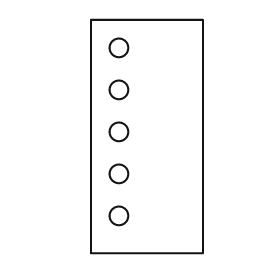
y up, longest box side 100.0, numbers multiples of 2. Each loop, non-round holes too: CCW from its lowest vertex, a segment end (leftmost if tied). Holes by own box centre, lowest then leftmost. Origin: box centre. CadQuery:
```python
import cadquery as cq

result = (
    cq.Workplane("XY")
    .moveTo(-24.0, -50.0)
    .lineTo(24.0, -50.0)
    .lineTo(24.0, 50.0)
    .lineTo(-24.0, 50.0)
    .close()
    .moveTo(-12.0, -34.0)
    .circle(4.0)
    .moveTo(-12.0, -16.0)
    .circle(4.0)
    .moveTo(-12.0, 2.0)
    .circle(4.0)
    .moveTo(-12.0, 20.0)
    .circle(4.0)
    .moveTo(-12.0, 38.0)
    .circle(4.0)
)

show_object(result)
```